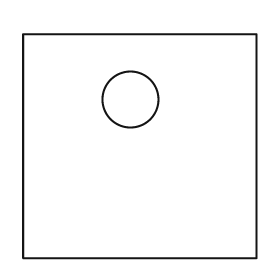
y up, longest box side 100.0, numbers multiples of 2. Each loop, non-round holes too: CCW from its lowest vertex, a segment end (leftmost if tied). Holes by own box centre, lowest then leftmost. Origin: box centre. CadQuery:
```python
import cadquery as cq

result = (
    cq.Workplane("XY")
    .moveTo(-50.0, -48.0)
    .lineTo(50.0, -48.0)
    .lineTo(50.0, 48.0)
    .lineTo(-50.0, 48.0)
    .close()
    .moveTo(-4.0, 20.0)
    .circle(12.0)
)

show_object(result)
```